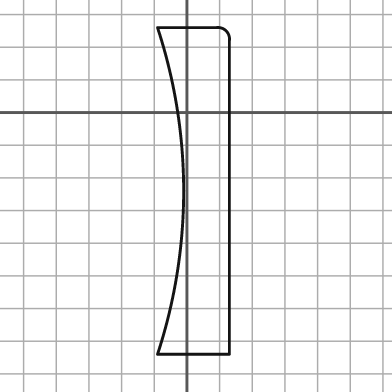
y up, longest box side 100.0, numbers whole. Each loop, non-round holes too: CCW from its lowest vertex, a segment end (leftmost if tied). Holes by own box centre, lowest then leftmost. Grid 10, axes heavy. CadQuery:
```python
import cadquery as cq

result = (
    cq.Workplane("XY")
    .moveTo(-9.0, -74.0)
    .lineTo(13.0, -74.0)
    .lineTo(13.0, 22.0)
    .threePointArc((12.0, 25.0), (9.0, 26.0))
    .lineTo(-9.0, 26.0)
    .threePointArc((-1.0, -24.0), (-9.0, -74.0))
    .close()
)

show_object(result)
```